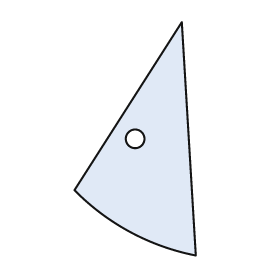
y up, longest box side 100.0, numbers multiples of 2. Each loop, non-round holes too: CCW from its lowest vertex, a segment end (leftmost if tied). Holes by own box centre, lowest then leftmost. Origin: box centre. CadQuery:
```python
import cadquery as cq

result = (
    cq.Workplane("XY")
    .moveTo(26.0, -50.0)
    .lineTo(20.0, 50.0)
    .lineTo(-26.0, -22.0)
    .threePointArc((-2.0, -40.0), (26.0, -50.0))
    .close()
    .moveTo(0.0, 0.0)
    .circle(4.0)
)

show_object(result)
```